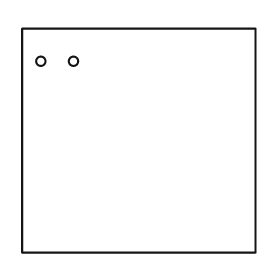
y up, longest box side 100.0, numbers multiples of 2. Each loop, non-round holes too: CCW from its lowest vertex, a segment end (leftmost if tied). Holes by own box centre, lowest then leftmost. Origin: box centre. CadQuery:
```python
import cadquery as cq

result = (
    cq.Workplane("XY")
    .moveTo(-50.0, -48.0)
    .lineTo(50.0, -48.0)
    .lineTo(50.0, 48.0)
    .lineTo(-50.0, 48.0)
    .close()
    .moveTo(-42.0, 34.0)
    .circle(2.0)
    .moveTo(-28.0, 34.0)
    .circle(2.0)
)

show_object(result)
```